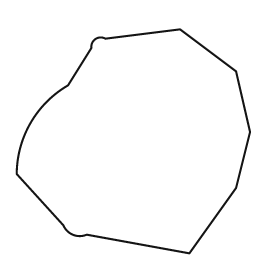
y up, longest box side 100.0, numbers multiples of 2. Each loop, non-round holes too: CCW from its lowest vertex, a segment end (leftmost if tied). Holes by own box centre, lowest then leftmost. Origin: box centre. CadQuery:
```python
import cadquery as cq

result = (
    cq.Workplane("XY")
    .moveTo(24.0, -48.0)
    .lineTo(44.0, -20.0)
    .lineTo(50.0, 4.0)
    .lineTo(44.0, 30.0)
    .lineTo(20.0, 48.0)
    .lineTo(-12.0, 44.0)
    .threePointArc((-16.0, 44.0), (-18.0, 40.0))
    .lineTo(-28.0, 24.0)
    .threePointArc((-44.0, 8.0), (-50.0, -14.0))
    .lineTo(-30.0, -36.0)
    .threePointArc((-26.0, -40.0), (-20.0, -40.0))
    .close()
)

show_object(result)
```